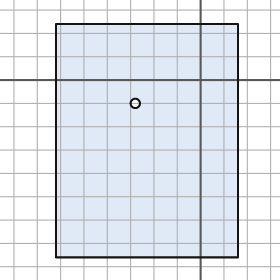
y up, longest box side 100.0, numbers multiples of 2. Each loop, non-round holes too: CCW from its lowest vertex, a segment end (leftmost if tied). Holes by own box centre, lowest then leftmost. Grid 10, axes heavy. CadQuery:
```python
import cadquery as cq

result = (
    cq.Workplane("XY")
    .moveTo(-62.0, -76.0)
    .lineTo(16.0, -76.0)
    .lineTo(16.0, 24.0)
    .lineTo(-62.0, 24.0)
    .close()
    .moveTo(-28.0, -10.0)
    .circle(2.0)
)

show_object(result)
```